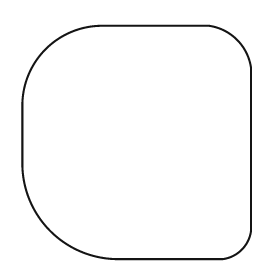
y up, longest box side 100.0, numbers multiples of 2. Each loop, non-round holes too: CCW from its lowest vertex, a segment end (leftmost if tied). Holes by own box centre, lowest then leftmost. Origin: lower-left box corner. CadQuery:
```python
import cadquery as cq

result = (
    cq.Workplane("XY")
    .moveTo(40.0, 0.0)
    .lineTo(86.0, 0.0)
    .threePointArc((94.0, 4.0), (98.0, 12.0))
    .lineTo(98.0, 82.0)
    .threePointArc((92.0, 94.0), (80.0, 100.0))
    .lineTo(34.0, 100.0)
    .threePointArc((10.0, 90.0), (0.0, 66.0))
    .lineTo(0.0, 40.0)
    .threePointArc((12.0, 12.0), (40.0, 0.0))
    .close()
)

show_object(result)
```